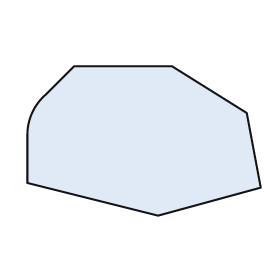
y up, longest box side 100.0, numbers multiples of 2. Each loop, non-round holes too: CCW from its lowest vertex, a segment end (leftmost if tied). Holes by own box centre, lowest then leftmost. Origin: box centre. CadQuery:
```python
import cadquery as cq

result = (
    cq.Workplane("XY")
    .moveTo(6.0, -32.0)
    .lineTo(50.0, -20.0)
    .lineTo(44.0, 12.0)
    .lineTo(12.0, 32.0)
    .lineTo(-30.0, 32.0)
    .lineTo(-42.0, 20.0)
    .threePointArc((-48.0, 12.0), (-50.0, 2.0))
    .lineTo(-50.0, -18.0)
    .close()
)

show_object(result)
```